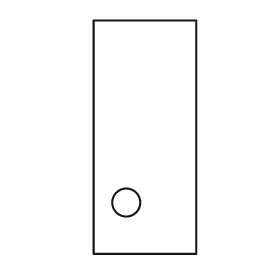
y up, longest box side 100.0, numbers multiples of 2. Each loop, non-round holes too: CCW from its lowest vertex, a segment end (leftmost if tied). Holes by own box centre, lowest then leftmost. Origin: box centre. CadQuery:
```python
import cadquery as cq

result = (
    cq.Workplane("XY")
    .moveTo(-22.0, -50.0)
    .lineTo(22.0, -50.0)
    .lineTo(22.0, 50.0)
    .lineTo(-22.0, 50.0)
    .close()
    .moveTo(-8.0, -28.0)
    .circle(6.0)
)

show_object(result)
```